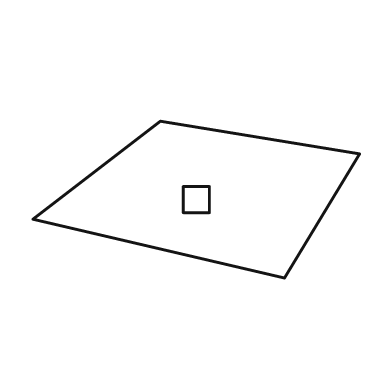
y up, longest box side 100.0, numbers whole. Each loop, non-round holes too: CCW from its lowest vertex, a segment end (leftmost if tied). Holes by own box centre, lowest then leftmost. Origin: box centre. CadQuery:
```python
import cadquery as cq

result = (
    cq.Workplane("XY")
    .moveTo(27.0, -24.0)
    .lineTo(50.0, 14.0)
    .lineTo(-11.0, 24.0)
    .lineTo(-50.0, -6.0)
    .close()
    .moveTo(-4.0, -4.0)
    .lineTo(4.0, -4.0)
    .lineTo(4.0, 4.0)
    .lineTo(-4.0, 4.0)
    .close()
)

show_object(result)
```